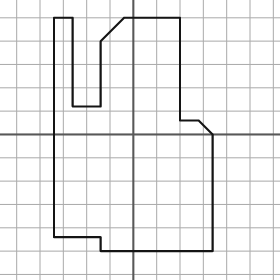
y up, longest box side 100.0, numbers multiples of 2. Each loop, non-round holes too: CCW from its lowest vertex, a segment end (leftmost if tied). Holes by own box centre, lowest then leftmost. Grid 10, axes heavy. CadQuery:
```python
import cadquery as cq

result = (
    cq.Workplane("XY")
    .moveTo(-14.0, -50.0)
    .lineTo(34.0, -50.0)
    .lineTo(34.0, 0.0)
    .lineTo(28.0, 6.0)
    .lineTo(20.0, 6.0)
    .lineTo(20.0, 50.0)
    .lineTo(-4.0, 50.0)
    .lineTo(-14.0, 40.0)
    .lineTo(-14.0, 12.0)
    .lineTo(-26.0, 12.0)
    .lineTo(-26.0, 50.0)
    .lineTo(-34.0, 50.0)
    .lineTo(-34.0, -44.0)
    .lineTo(-14.0, -44.0)
    .close()
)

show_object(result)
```